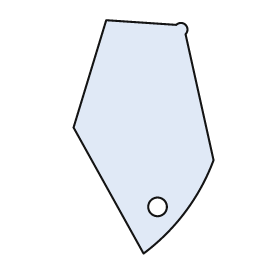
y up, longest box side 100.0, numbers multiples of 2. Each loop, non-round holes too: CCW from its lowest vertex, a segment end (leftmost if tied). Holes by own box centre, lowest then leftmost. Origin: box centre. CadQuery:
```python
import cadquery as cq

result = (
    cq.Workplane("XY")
    .moveTo(0.0, -50.0)
    .threePointArc((18.0, -32.0), (30.0, -10.0))
    .lineTo(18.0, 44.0)
    .threePointArc((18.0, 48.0), (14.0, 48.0))
    .lineTo(-16.0, 50.0)
    .lineTo(-30.0, 4.0)
    .close()
    .moveTo(6.0, -30.0)
    .circle(4.0)
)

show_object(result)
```